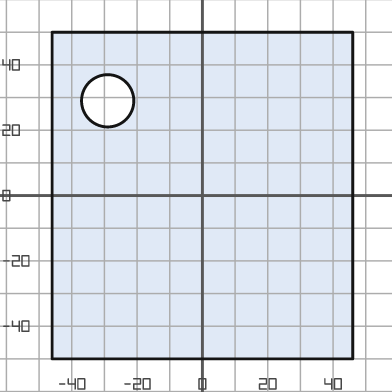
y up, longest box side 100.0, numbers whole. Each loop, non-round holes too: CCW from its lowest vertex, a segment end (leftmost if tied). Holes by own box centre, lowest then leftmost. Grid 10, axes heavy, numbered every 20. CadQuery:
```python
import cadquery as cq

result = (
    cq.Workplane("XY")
    .moveTo(-46.0, -50.0)
    .lineTo(46.0, -50.0)
    .lineTo(46.0, 50.0)
    .lineTo(-46.0, 50.0)
    .close()
    .moveTo(-29.0, 29.0)
    .circle(8.0)
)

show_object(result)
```